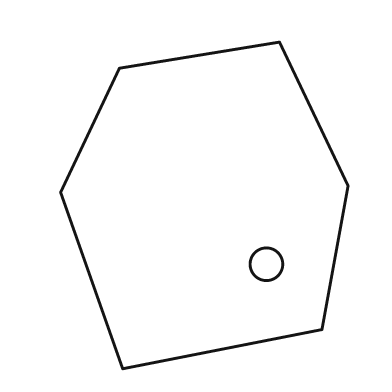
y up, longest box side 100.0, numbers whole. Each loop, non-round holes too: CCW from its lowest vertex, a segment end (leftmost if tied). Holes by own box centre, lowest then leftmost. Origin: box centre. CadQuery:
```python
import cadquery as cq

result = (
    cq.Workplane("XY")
    .moveTo(-25.0, -50.0)
    .lineTo(36.0, -38.0)
    .lineTo(44.0, 6.0)
    .lineTo(23.0, 50.0)
    .lineTo(-26.0, 42.0)
    .lineTo(-44.0, 4.0)
    .close()
    .moveTo(19.0, -18.0)
    .circle(5.0)
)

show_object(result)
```